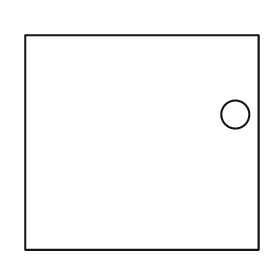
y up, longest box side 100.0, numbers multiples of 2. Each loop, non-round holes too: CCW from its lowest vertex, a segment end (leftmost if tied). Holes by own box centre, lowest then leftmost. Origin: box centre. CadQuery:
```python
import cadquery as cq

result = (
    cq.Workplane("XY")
    .moveTo(-50.0, -46.0)
    .lineTo(50.0, -46.0)
    .lineTo(50.0, 46.0)
    .lineTo(-50.0, 46.0)
    .close()
    .moveTo(40.0, 12.0)
    .circle(6.0)
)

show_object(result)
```